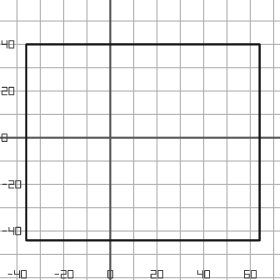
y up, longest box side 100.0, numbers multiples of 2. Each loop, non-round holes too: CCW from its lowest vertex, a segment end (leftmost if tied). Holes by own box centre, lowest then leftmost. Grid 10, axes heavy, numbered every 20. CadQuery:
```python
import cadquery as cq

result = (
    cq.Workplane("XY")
    .moveTo(-36.0, -44.0)
    .lineTo(64.0, -44.0)
    .lineTo(64.0, 40.0)
    .lineTo(-36.0, 40.0)
    .close()
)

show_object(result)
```